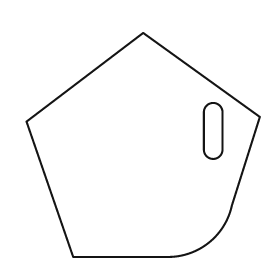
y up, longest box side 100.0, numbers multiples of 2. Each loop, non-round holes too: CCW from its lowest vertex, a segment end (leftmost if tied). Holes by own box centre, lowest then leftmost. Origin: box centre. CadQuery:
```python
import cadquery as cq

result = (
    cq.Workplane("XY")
    .moveTo(-30.0, -48.0)
    .lineTo(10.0, -48.0)
    .threePointArc((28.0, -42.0), (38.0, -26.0))
    .lineTo(50.0, 12.0)
    .lineTo(0.0, 48.0)
    .lineTo(-50.0, 10.0)
    .close()
    .moveTo(26.0, -2.0)
    .threePointArc((30.0, -6.0), (34.0, -2.0))
    .lineTo(34.0, 14.0)
    .threePointArc((30.0, 18.0), (26.0, 14.0))
    .close()
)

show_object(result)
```